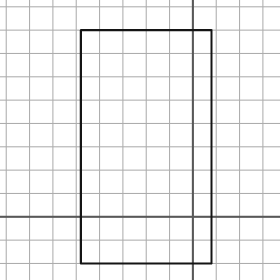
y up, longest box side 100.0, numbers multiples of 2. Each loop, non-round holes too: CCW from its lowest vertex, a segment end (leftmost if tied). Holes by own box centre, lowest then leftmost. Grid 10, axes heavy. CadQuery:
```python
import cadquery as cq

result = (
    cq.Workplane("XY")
    .moveTo(-48.0, -20.0)
    .lineTo(8.0, -20.0)
    .lineTo(8.0, 80.0)
    .lineTo(-48.0, 80.0)
    .close()
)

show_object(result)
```